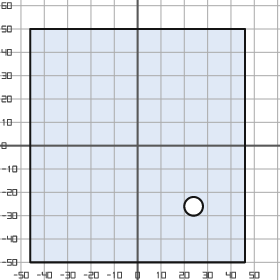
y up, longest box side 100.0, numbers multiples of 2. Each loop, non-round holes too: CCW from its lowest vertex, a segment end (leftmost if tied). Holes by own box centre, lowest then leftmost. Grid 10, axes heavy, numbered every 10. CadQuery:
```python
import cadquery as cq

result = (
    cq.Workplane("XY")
    .moveTo(-46.0, -50.0)
    .lineTo(46.0, -50.0)
    .lineTo(46.0, 50.0)
    .lineTo(-46.0, 50.0)
    .close()
    .moveTo(24.0, -26.0)
    .circle(4.0)
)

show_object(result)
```